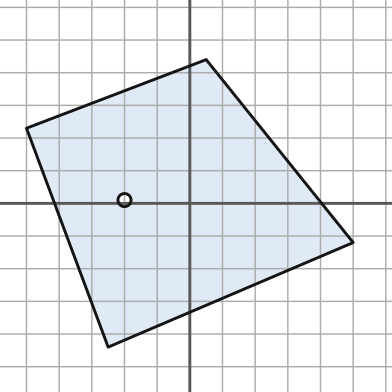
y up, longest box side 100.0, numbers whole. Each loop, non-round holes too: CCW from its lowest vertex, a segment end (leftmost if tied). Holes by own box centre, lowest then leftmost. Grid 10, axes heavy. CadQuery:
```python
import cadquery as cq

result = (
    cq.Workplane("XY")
    .moveTo(-25.0, -44.0)
    .lineTo(50.0, -12.0)
    .lineTo(5.0, 44.0)
    .lineTo(-50.0, 23.0)
    .close()
    .moveTo(-20.0, 1.0)
    .circle(2.0)
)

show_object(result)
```